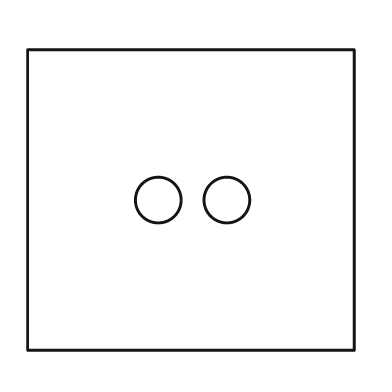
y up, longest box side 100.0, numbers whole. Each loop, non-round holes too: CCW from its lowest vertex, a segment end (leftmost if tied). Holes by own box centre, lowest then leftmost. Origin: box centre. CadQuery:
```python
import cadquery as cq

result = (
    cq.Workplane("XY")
    .moveTo(-50.0, -46.0)
    .lineTo(50.0, -46.0)
    .lineTo(50.0, 46.0)
    .lineTo(-50.0, 46.0)
    .close()
    .moveTo(-10.0, 0.0)
    .circle(7.0)
    .moveTo(11.0, 0.0)
    .circle(7.0)
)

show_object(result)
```